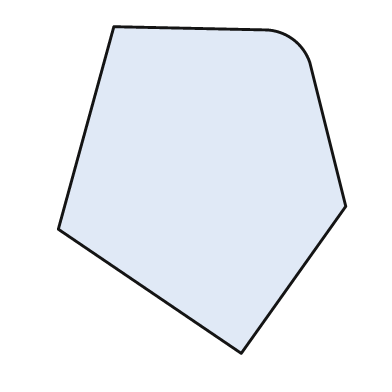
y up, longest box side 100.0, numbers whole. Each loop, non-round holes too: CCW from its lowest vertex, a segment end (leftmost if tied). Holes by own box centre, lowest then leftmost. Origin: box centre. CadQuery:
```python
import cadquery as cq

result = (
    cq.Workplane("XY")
    .moveTo(12.0, -50.0)
    .lineTo(44.0, -5.0)
    .lineTo(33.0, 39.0)
    .threePointArc((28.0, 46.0), (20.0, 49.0))
    .lineTo(-27.0, 50.0)
    .lineTo(-44.0, -12.0)
    .close()
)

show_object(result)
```